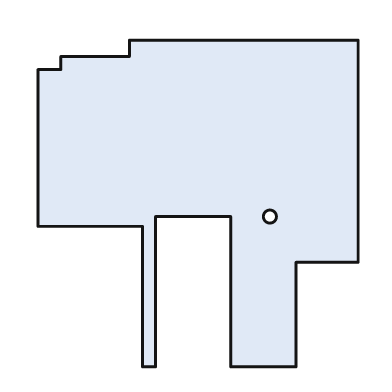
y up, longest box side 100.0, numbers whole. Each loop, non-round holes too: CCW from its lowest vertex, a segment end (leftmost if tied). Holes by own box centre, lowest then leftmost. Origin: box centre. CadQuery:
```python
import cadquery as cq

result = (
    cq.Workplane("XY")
    .moveTo(-17.0, -50.0)
    .lineTo(-13.0, -50.0)
    .lineTo(-13.0, -4.0)
    .lineTo(10.0, -4.0)
    .lineTo(10.0, -50.0)
    .lineTo(30.0, -50.0)
    .lineTo(30.0, -18.0)
    .lineTo(49.0, -18.0)
    .lineTo(49.0, 50.0)
    .lineTo(-21.0, 50.0)
    .lineTo(-21.0, 45.0)
    .lineTo(-42.0, 45.0)
    .lineTo(-42.0, 41.0)
    .lineTo(-49.0, 41.0)
    .lineTo(-49.0, -7.0)
    .lineTo(-17.0, -7.0)
    .close()
    .moveTo(22.0, -4.0)
    .circle(2.0)
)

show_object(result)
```